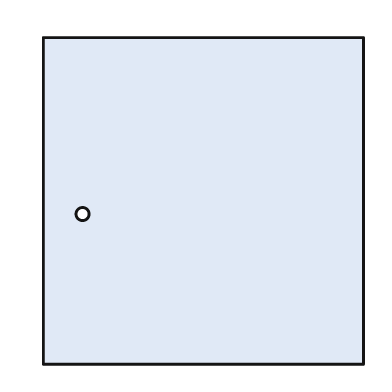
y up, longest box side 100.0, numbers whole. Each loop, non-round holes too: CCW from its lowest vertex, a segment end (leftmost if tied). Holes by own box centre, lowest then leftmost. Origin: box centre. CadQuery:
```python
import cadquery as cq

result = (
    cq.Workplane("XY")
    .moveTo(-49.0, -50.0)
    .lineTo(49.0, -50.0)
    .lineTo(49.0, 50.0)
    .lineTo(-49.0, 50.0)
    .close()
    .moveTo(-37.0, -4.0)
    .circle(2.0)
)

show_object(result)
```